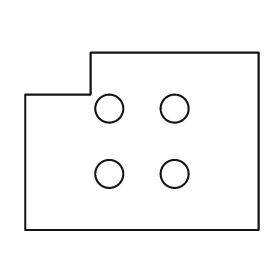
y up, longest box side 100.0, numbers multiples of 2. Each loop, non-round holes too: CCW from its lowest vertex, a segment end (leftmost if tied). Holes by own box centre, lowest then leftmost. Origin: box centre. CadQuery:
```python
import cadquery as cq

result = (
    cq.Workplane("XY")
    .moveTo(-50.0, -38.0)
    .lineTo(50.0, -38.0)
    .lineTo(50.0, 38.0)
    .lineTo(-22.0, 38.0)
    .lineTo(-22.0, 20.0)
    .lineTo(-50.0, 20.0)
    .close()
    .moveTo(-14.0, -14.0)
    .circle(6.0)
    .moveTo(14.0, -14.0)
    .circle(6.0)
    .moveTo(-14.0, 14.0)
    .circle(6.0)
    .moveTo(14.0, 14.0)
    .circle(6.0)
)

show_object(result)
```